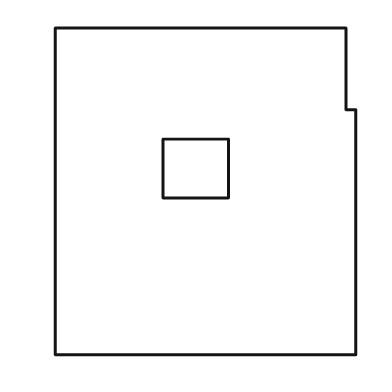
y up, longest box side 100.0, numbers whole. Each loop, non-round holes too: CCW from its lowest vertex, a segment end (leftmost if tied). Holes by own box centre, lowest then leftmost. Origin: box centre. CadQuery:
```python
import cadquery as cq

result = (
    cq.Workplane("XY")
    .moveTo(-46.0, -50.0)
    .lineTo(46.0, -50.0)
    .lineTo(46.0, 25.0)
    .lineTo(43.0, 25.0)
    .lineTo(43.0, 50.0)
    .lineTo(-46.0, 50.0)
    .close()
    .moveTo(-13.0, -2.0)
    .lineTo(7.0, -2.0)
    .lineTo(7.0, 16.0)
    .lineTo(-13.0, 16.0)
    .close()
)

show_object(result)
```